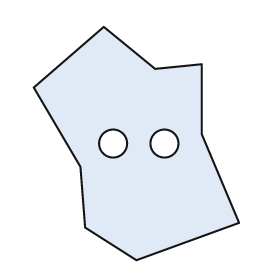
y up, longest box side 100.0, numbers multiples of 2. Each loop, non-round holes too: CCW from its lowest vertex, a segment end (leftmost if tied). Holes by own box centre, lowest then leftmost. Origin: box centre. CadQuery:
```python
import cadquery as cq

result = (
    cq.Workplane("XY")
    .moveTo(0.0, -50.0)
    .lineTo(44.0, -34.0)
    .lineTo(28.0, 4.0)
    .lineTo(28.0, 34.0)
    .lineTo(8.0, 32.0)
    .lineTo(-14.0, 50.0)
    .lineTo(-44.0, 24.0)
    .lineTo(-24.0, -10.0)
    .lineTo(-22.0, -36.0)
    .close()
    .moveTo(-10.0, 0.0)
    .circle(6.0)
    .moveTo(12.0, 0.0)
    .circle(6.0)
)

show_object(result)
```